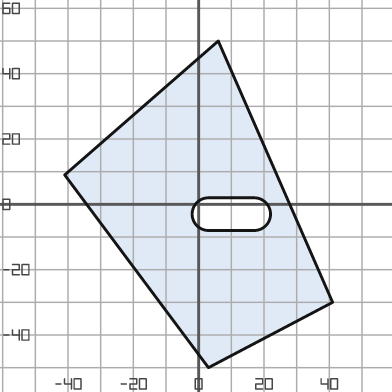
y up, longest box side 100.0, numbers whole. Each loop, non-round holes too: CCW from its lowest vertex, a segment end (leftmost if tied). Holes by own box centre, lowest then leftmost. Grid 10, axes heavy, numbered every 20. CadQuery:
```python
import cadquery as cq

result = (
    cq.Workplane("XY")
    .moveTo(3.0, -50.0)
    .lineTo(41.0, -30.0)
    .lineTo(6.0, 50.0)
    .lineTo(-41.0, 9.0)
    .close()
    .moveTo(3.0, -8.0)
    .lineTo(17.0, -8.0)
    .threePointArc((22.0, -3.0), (17.0, 2.0))
    .lineTo(3.0, 2.0)
    .threePointArc((-2.0, -3.0), (3.0, -8.0))
    .close()
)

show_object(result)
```